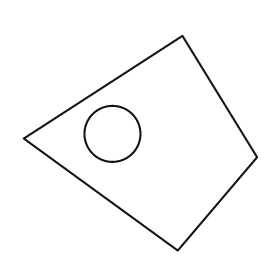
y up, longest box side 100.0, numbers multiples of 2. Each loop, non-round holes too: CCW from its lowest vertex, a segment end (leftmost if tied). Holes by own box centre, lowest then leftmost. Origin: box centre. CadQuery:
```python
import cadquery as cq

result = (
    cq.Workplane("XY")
    .moveTo(16.0, -46.0)
    .lineTo(50.0, -6.0)
    .lineTo(18.0, 46.0)
    .lineTo(-50.0, 2.0)
    .close()
    .moveTo(-12.0, 4.0)
    .circle(12.0)
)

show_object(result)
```